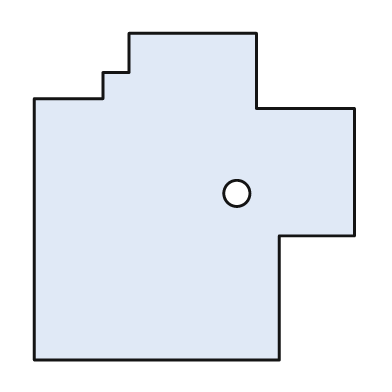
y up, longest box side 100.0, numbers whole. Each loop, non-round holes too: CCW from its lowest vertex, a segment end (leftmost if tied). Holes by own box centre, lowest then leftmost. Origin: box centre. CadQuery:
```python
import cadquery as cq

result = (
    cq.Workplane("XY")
    .moveTo(-49.0, -50.0)
    .lineTo(26.0, -50.0)
    .lineTo(26.0, -12.0)
    .lineTo(49.0, -12.0)
    .lineTo(49.0, 27.0)
    .lineTo(19.0, 27.0)
    .lineTo(19.0, 50.0)
    .lineTo(-20.0, 50.0)
    .lineTo(-20.0, 38.0)
    .lineTo(-28.0, 38.0)
    .lineTo(-28.0, 30.0)
    .lineTo(-49.0, 30.0)
    .close()
    .moveTo(13.0, 1.0)
    .circle(4.0)
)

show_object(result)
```